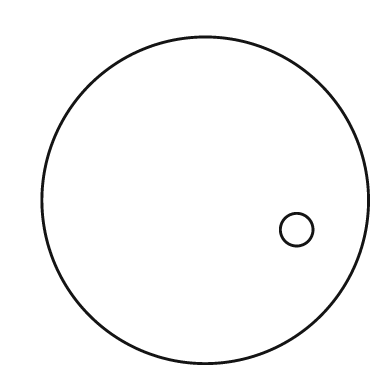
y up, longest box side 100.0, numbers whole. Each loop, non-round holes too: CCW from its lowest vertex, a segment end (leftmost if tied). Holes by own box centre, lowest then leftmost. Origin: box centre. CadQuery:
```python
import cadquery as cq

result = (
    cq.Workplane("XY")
    .moveTo(0.0, 0.0)
    .circle(50.0)
    .moveTo(28.0, -9.0)
    .circle(5.0)
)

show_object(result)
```